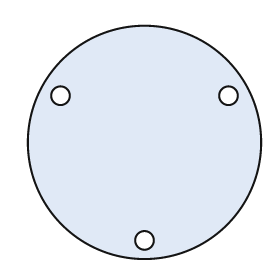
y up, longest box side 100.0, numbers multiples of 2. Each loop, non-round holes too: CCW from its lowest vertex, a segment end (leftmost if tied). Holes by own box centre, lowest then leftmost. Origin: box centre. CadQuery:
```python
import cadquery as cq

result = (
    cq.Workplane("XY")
    .moveTo(0.0, 0.0)
    .circle(50.0)
    .moveTo(0.0, -42.0)
    .circle(4.0)
    .moveTo(-36.0, 20.0)
    .circle(4.0)
    .moveTo(36.0, 20.0)
    .circle(4.0)
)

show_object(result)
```